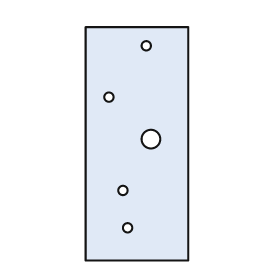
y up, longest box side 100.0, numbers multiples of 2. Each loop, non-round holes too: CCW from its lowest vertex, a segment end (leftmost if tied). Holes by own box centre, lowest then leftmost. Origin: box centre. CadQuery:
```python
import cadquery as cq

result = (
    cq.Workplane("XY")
    .moveTo(-22.0, -50.0)
    .lineTo(22.0, -50.0)
    .lineTo(22.0, 50.0)
    .lineTo(-22.0, 50.0)
    .close()
    .moveTo(-4.0, -36.0)
    .circle(2.0)
    .moveTo(-6.0, -20.0)
    .circle(2.0)
    .moveTo(6.0, 2.0)
    .circle(4.0)
    .moveTo(-12.0, 20.0)
    .circle(2.0)
    .moveTo(4.0, 42.0)
    .circle(2.0)
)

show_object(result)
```